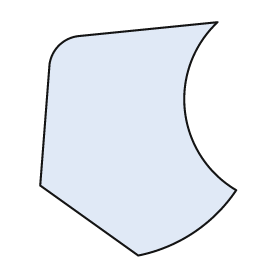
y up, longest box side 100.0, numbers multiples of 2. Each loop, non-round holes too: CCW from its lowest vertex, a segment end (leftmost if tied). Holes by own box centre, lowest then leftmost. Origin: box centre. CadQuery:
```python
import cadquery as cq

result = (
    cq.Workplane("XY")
    .moveTo(0.0, -50.0)
    .threePointArc((24.0, -40.0), (42.0, -22.0))
    .threePointArc((20.0, 12.0), (34.0, 50.0))
    .lineTo(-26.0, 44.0)
    .threePointArc((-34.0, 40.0), (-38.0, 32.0))
    .lineTo(-42.0, -20.0)
    .close()
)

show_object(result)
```